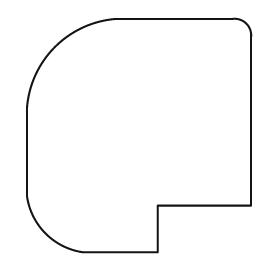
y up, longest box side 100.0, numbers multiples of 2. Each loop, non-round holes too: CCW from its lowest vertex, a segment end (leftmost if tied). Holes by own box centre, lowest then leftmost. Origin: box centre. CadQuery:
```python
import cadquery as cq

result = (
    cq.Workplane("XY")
    .moveTo(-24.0, -50.0)
    .lineTo(8.0, -50.0)
    .lineTo(8.0, -30.0)
    .lineTo(48.0, -30.0)
    .lineTo(48.0, 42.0)
    .threePointArc((46.0, 48.0), (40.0, 50.0))
    .lineTo(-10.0, 50.0)
    .threePointArc((-36.0, 38.0), (-48.0, 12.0))
    .lineTo(-48.0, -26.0)
    .threePointArc((-40.0, -42.0), (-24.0, -50.0))
    .close()
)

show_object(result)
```